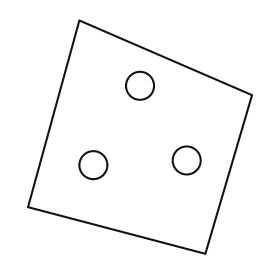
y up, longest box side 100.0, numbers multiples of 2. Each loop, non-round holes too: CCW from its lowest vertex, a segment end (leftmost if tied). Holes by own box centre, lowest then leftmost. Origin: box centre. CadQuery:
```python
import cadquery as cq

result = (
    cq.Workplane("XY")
    .moveTo(28.0, -50.0)
    .lineTo(48.0, 18.0)
    .lineTo(-26.0, 50.0)
    .lineTo(-48.0, -30.0)
    .close()
    .moveTo(-20.0, -12.0)
    .circle(6.0)
    .moveTo(20.0, -10.0)
    .circle(6.0)
    .moveTo(0.0, 22.0)
    .circle(6.0)
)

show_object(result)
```